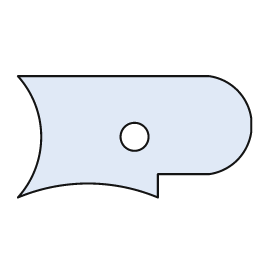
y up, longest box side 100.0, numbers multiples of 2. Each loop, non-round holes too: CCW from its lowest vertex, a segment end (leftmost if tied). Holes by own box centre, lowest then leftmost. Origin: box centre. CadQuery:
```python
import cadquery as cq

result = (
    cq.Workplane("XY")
    .moveTo(-50.0, -26.0)
    .threePointArc((-20.0, -20.0), (10.0, -26.0))
    .lineTo(10.0, -16.0)
    .lineTo(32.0, -16.0)
    .threePointArc((44.0, -10.0), (50.0, 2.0))
    .lineTo(50.0, 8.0)
    .threePointArc((44.0, 20.0), (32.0, 26.0))
    .lineTo(-50.0, 26.0)
    .threePointArc((-40.0, 0.0), (-50.0, -26.0))
    .close()
    .moveTo(0.0, 0.0)
    .circle(6.0)
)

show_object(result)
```